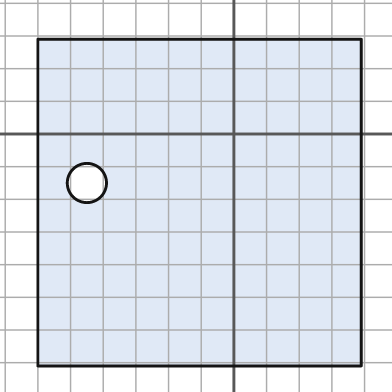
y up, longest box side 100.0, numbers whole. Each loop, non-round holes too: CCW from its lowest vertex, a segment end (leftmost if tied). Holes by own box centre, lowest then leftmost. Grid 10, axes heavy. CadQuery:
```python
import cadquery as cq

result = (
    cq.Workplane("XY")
    .moveTo(-60.0, -71.0)
    .lineTo(39.0, -71.0)
    .lineTo(39.0, 29.0)
    .lineTo(-60.0, 29.0)
    .close()
    .moveTo(-45.0, -15.0)
    .circle(6.0)
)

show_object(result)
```